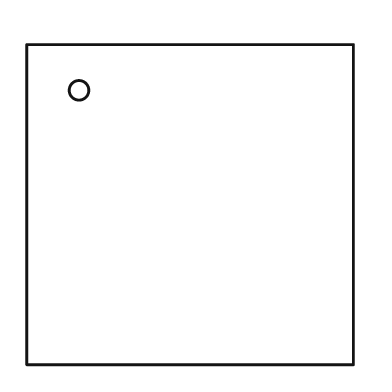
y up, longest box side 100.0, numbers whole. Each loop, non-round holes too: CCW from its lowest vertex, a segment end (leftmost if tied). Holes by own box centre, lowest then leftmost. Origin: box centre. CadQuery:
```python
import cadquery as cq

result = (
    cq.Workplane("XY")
    .moveTo(-50.0, -49.0)
    .lineTo(50.0, -49.0)
    .lineTo(50.0, 49.0)
    .lineTo(-50.0, 49.0)
    .close()
    .moveTo(-34.0, 35.0)
    .circle(3.0)
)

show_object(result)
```